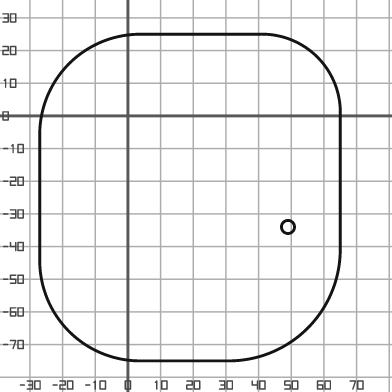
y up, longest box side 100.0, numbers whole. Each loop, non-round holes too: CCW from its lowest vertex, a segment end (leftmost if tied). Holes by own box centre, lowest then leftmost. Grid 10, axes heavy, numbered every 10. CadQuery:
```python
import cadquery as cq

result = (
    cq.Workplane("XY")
    .moveTo(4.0, -75.0)
    .lineTo(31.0, -75.0)
    .threePointArc((55.0, -65.0), (65.0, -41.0))
    .lineTo(65.0, 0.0)
    .threePointArc((58.0, 18.0), (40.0, 25.0))
    .lineTo(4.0, 25.0)
    .threePointArc((-18.0, 16.0), (-27.0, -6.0))
    .lineTo(-27.0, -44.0)
    .threePointArc((-18.0, -66.0), (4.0, -75.0))
    .close()
    .moveTo(49.0, -34.0)
    .circle(2.0)
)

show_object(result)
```